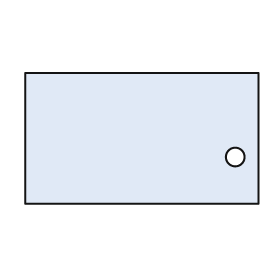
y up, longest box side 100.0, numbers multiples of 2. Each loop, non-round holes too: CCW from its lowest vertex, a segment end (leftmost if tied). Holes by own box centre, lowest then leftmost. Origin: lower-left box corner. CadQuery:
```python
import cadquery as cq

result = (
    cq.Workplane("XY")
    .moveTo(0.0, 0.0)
    .lineTo(100.0, 0.0)
    .lineTo(100.0, 56.0)
    .lineTo(0.0, 56.0)
    .close()
    .moveTo(90.0, 20.0)
    .circle(4.0)
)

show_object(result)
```